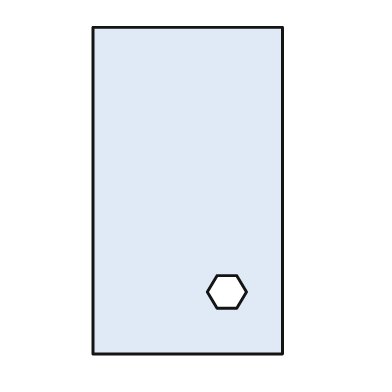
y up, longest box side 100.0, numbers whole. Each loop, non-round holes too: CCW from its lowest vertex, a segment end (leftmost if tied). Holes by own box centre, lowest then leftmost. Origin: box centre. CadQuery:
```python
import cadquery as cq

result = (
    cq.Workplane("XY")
    .moveTo(-29.0, -50.0)
    .lineTo(29.0, -50.0)
    .lineTo(29.0, 50.0)
    .lineTo(-29.0, 50.0)
    .close()
    .moveTo(9.0, -36.0)
    .lineTo(15.0, -36.0)
    .lineTo(18.0, -31.0)
    .lineTo(15.0, -26.0)
    .lineTo(9.0, -26.0)
    .lineTo(6.0, -31.0)
    .close()
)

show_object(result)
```